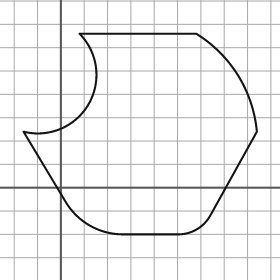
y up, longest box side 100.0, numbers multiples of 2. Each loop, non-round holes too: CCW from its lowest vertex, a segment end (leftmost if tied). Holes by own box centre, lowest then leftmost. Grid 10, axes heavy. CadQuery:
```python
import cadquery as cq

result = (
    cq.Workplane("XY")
    .moveTo(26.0, -20.0)
    .lineTo(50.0, -20.0)
    .threePointArc((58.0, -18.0), (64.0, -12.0))
    .lineTo(84.0, 24.0)
    .threePointArc((76.0, 48.0), (58.0, 66.0))
    .lineTo(8.0, 66.0)
    .threePointArc((12.0, 36.0), (-16.0, 24.0))
    .lineTo(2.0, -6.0)
    .threePointArc((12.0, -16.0), (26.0, -20.0))
    .close()
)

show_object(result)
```